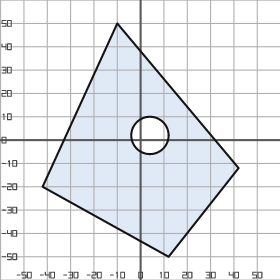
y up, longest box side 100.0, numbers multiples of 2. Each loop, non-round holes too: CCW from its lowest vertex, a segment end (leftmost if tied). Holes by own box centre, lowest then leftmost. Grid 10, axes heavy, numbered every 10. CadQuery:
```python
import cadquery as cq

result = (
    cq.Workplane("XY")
    .moveTo(12.0, -50.0)
    .lineTo(42.0, -12.0)
    .lineTo(-10.0, 50.0)
    .lineTo(-42.0, -20.0)
    .close()
    .moveTo(4.0, 2.0)
    .circle(8.0)
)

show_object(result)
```